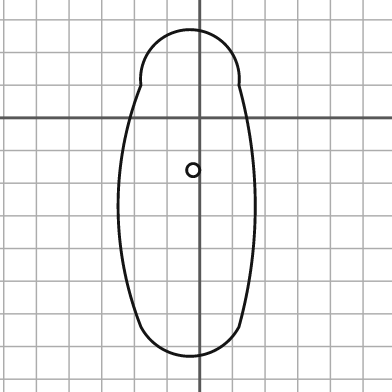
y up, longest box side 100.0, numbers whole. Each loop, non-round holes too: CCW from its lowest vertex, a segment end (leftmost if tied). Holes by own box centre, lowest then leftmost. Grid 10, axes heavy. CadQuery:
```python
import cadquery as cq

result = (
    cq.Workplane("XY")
    .moveTo(-18.0, -64.0)
    .threePointArc((-3.0, -73.0), (12.0, -64.0))
    .threePointArc((17.0, -27.0), (12.0, 10.0))
    .threePointArc((-3.0, 27.0), (-18.0, 10.0))
    .threePointArc((-25.0, -27.0), (-18.0, -64.0))
    .close()
    .moveTo(-2.0, -16.0)
    .circle(2.0)
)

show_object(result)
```